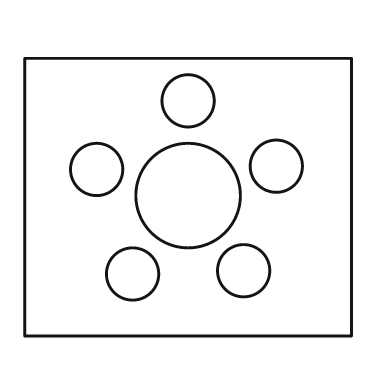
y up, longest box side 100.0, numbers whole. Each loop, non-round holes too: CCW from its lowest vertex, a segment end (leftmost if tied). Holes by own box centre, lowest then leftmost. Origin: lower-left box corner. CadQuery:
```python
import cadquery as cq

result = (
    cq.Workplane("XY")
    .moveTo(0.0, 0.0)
    .lineTo(100.0, 0.0)
    .lineTo(100.0, 85.0)
    .lineTo(0.0, 85.0)
    .close()
    .moveTo(33.0, 19.0)
    .circle(8.0)
    .moveTo(67.0, 20.0)
    .circle(8.0)
    .moveTo(50.0, 43.0)
    .circle(16.0)
    .moveTo(22.0, 51.0)
    .circle(8.0)
    .moveTo(77.0, 52.0)
    .circle(8.0)
    .moveTo(50.0, 72.0)
    .circle(8.0)
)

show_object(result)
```